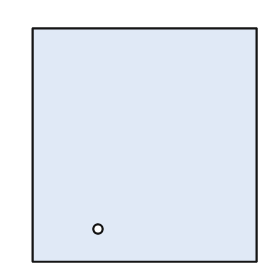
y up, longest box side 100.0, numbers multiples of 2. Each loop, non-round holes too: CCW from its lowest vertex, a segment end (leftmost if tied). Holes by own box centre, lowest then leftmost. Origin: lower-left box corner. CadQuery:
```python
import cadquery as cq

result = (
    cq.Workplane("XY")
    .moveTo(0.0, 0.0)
    .lineTo(96.0, 0.0)
    .lineTo(96.0, 100.0)
    .lineTo(0.0, 100.0)
    .close()
    .moveTo(28.0, 14.0)
    .circle(2.0)
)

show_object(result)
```